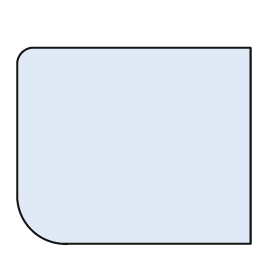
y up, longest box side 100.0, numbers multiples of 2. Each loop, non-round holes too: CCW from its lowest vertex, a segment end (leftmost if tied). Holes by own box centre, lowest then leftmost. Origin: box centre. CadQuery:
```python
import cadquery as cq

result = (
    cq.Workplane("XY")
    .moveTo(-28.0, -42.0)
    .lineTo(50.0, -42.0)
    .lineTo(50.0, 42.0)
    .lineTo(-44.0, 42.0)
    .threePointArc((-48.0, 40.0), (-50.0, 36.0))
    .lineTo(-50.0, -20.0)
    .threePointArc((-44.0, -36.0), (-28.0, -42.0))
    .close()
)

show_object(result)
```